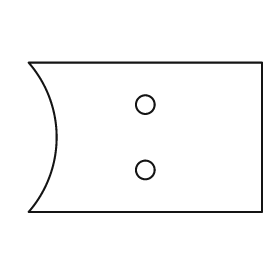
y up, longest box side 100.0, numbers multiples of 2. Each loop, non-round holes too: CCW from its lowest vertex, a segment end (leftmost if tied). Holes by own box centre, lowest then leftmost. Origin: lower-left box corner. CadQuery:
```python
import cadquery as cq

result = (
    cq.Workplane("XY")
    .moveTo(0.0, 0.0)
    .lineTo(100.0, 0.0)
    .lineTo(100.0, 64.0)
    .lineTo(0.0, 64.0)
    .threePointArc((12.0, 32.0), (0.0, 0.0))
    .close()
    .moveTo(50.0, 18.0)
    .circle(4.0)
    .moveTo(50.0, 46.0)
    .circle(4.0)
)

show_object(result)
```